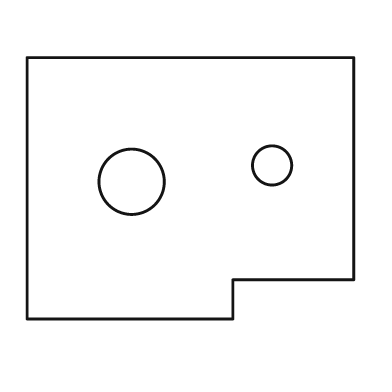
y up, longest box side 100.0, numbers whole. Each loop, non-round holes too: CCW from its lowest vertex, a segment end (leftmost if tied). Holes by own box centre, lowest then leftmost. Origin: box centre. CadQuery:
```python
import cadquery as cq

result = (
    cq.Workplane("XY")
    .moveTo(-50.0, -40.0)
    .lineTo(13.0, -40.0)
    .lineTo(13.0, -28.0)
    .lineTo(50.0, -28.0)
    .lineTo(50.0, 40.0)
    .lineTo(-50.0, 40.0)
    .close()
    .moveTo(-18.0, 2.0)
    .circle(10.0)
    .moveTo(25.0, 7.0)
    .circle(6.0)
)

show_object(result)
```